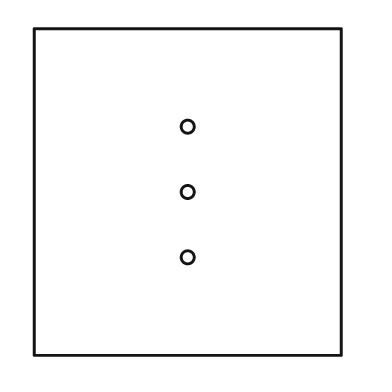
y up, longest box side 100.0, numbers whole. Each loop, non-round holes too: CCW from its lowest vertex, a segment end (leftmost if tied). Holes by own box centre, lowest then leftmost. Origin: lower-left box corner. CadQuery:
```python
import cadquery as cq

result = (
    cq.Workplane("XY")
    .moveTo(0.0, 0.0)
    .lineTo(94.0, 0.0)
    .lineTo(94.0, 100.0)
    .lineTo(0.0, 100.0)
    .close()
    .moveTo(47.0, 30.0)
    .circle(2.0)
    .moveTo(47.0, 50.0)
    .circle(2.0)
    .moveTo(47.0, 70.0)
    .circle(2.0)
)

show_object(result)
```